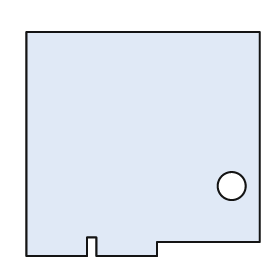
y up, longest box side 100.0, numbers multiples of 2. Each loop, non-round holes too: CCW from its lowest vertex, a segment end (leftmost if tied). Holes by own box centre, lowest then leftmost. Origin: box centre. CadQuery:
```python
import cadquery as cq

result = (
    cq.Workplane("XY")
    .moveTo(-50.0, -48.0)
    .lineTo(-24.0, -48.0)
    .lineTo(-24.0, -40.0)
    .lineTo(-20.0, -40.0)
    .lineTo(-20.0, -48.0)
    .lineTo(6.0, -48.0)
    .lineTo(6.0, -42.0)
    .lineTo(50.0, -42.0)
    .lineTo(50.0, 48.0)
    .lineTo(-50.0, 48.0)
    .close()
    .moveTo(38.0, -18.0)
    .circle(6.0)
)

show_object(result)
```